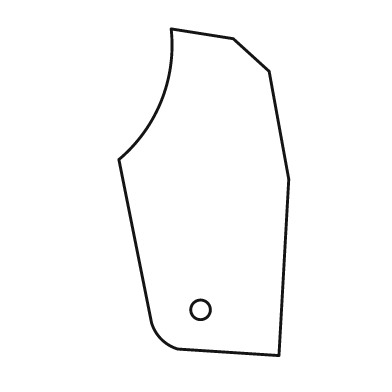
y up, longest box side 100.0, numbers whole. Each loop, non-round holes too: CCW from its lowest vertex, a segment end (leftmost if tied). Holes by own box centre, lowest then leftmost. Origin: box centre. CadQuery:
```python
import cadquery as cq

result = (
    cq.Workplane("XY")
    .moveTo(23.0, -50.0)
    .lineTo(26.0, 4.0)
    .lineTo(20.0, 37.0)
    .lineTo(9.0, 47.0)
    .lineTo(-10.0, 50.0)
    .threePointArc((-13.0, 28.0), (-26.0, 10.0))
    .lineTo(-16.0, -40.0)
    .threePointArc((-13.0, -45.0), (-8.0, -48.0))
    .close()
    .moveTo(-1.0, -36.0)
    .circle(3.0)
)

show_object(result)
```